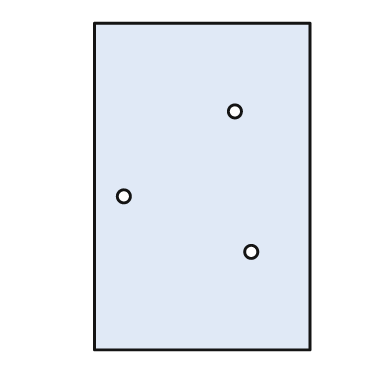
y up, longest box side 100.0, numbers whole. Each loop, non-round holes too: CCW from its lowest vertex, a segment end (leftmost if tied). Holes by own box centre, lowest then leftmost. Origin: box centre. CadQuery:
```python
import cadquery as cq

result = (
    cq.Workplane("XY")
    .moveTo(-33.0, -50.0)
    .lineTo(33.0, -50.0)
    .lineTo(33.0, 50.0)
    .lineTo(-33.0, 50.0)
    .close()
    .moveTo(15.0, -20.0)
    .circle(2.0)
    .moveTo(-24.0, -3.0)
    .circle(2.0)
    .moveTo(10.0, 23.0)
    .circle(2.0)
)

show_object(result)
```